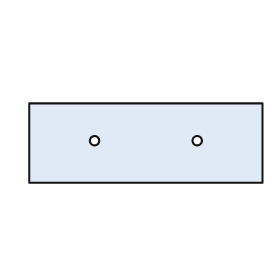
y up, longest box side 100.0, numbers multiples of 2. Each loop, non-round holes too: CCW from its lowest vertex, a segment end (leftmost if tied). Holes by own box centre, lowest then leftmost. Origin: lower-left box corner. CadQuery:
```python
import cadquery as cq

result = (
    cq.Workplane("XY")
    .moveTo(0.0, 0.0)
    .lineTo(100.0, 0.0)
    .lineTo(100.0, 34.0)
    .lineTo(0.0, 34.0)
    .close()
    .moveTo(28.0, 18.0)
    .circle(2.0)
    .moveTo(72.0, 18.0)
    .circle(2.0)
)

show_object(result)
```